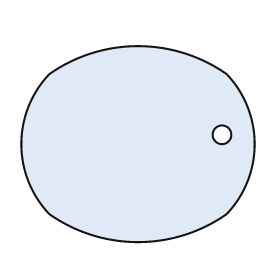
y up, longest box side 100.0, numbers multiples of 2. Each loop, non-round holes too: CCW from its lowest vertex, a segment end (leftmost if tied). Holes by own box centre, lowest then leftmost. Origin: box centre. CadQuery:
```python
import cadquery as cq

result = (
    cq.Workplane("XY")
    .moveTo(-38.0, -30.0)
    .threePointArc((0.0, -42.0), (38.0, -30.0))
    .threePointArc((50.0, 0.0), (38.0, 30.0))
    .threePointArc((0.0, 42.0), (-38.0, 30.0))
    .threePointArc((-50.0, 0.0), (-38.0, -30.0))
    .close()
    .moveTo(36.0, 4.0)
    .circle(4.0)
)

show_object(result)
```